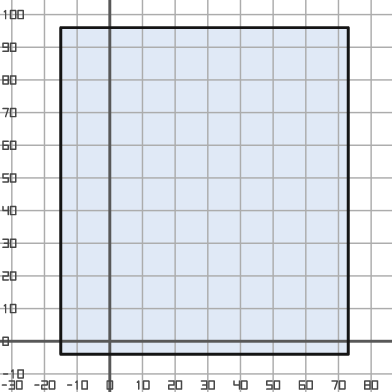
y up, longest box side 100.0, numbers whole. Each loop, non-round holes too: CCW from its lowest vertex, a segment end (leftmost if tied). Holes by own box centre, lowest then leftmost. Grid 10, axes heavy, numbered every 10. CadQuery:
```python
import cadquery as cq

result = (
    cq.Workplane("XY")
    .moveTo(-15.0, -4.0)
    .lineTo(73.0, -4.0)
    .lineTo(73.0, 96.0)
    .lineTo(-15.0, 96.0)
    .close()
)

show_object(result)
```